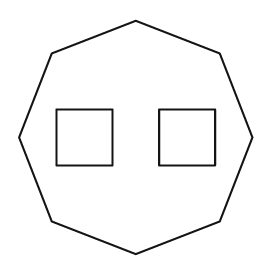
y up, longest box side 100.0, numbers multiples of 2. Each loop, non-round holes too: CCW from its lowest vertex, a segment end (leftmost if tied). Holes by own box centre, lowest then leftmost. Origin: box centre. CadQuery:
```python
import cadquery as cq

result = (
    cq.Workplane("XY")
    .moveTo(0.0, -50.0)
    .lineTo(36.0, -36.0)
    .lineTo(50.0, 0.0)
    .lineTo(36.0, 36.0)
    .lineTo(0.0, 50.0)
    .lineTo(-36.0, 36.0)
    .lineTo(-50.0, 0.0)
    .lineTo(-36.0, -36.0)
    .close()
    .moveTo(-34.0, -12.0)
    .lineTo(-10.0, -12.0)
    .lineTo(-10.0, 12.0)
    .lineTo(-34.0, 12.0)
    .close()
    .moveTo(10.0, -12.0)
    .lineTo(34.0, -12.0)
    .lineTo(34.0, 12.0)
    .lineTo(10.0, 12.0)
    .close()
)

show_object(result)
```